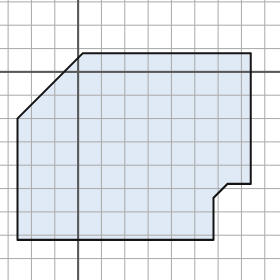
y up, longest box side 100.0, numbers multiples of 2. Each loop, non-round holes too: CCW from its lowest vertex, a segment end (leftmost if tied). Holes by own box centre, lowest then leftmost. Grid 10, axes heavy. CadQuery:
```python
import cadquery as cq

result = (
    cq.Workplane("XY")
    .moveTo(-26.0, -72.0)
    .lineTo(58.0, -72.0)
    .lineTo(58.0, -54.0)
    .lineTo(64.0, -48.0)
    .lineTo(74.0, -48.0)
    .lineTo(74.0, 8.0)
    .lineTo(2.0, 8.0)
    .lineTo(-26.0, -20.0)
    .close()
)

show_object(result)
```